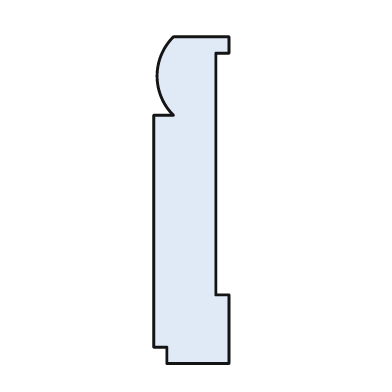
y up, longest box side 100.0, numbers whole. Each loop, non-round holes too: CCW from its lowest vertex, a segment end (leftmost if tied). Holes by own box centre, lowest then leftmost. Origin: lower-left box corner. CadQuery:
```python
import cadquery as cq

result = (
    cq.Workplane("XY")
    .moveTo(4.0, 0.0)
    .lineTo(23.0, 0.0)
    .lineTo(23.0, 21.0)
    .lineTo(19.0, 21.0)
    .lineTo(19.0, 95.0)
    .lineTo(23.0, 95.0)
    .lineTo(23.0, 100.0)
    .lineTo(6.0, 100.0)
    .threePointArc((1.0, 88.0), (6.0, 76.0))
    .lineTo(0.0, 76.0)
    .lineTo(0.0, 5.0)
    .lineTo(4.0, 5.0)
    .close()
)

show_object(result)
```